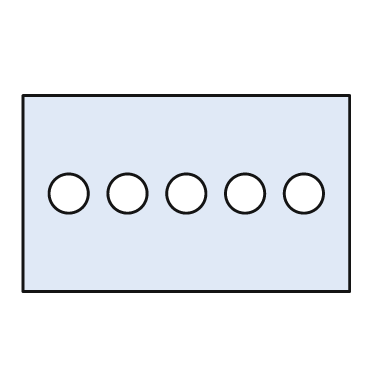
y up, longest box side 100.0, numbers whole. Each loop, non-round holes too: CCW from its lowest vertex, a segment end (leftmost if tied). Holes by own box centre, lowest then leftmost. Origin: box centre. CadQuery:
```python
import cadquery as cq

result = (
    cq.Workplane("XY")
    .moveTo(-50.0, -30.0)
    .lineTo(50.0, -30.0)
    .lineTo(50.0, 30.0)
    .lineTo(-50.0, 30.0)
    .close()
    .moveTo(-36.0, 0.0)
    .circle(6.0)
    .moveTo(-18.0, 0.0)
    .circle(6.0)
    .moveTo(0.0, 0.0)
    .circle(6.0)
    .moveTo(18.0, 0.0)
    .circle(6.0)
    .moveTo(36.0, 0.0)
    .circle(6.0)
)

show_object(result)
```